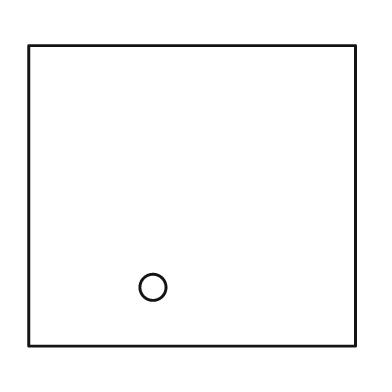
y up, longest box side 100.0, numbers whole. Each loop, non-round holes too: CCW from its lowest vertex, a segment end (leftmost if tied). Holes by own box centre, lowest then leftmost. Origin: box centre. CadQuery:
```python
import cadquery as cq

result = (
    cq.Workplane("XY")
    .moveTo(-50.0, -46.0)
    .lineTo(50.0, -46.0)
    .lineTo(50.0, 46.0)
    .lineTo(-50.0, 46.0)
    .close()
    .moveTo(-12.0, -28.0)
    .circle(4.0)
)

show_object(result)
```